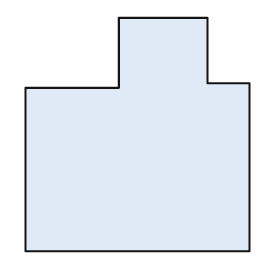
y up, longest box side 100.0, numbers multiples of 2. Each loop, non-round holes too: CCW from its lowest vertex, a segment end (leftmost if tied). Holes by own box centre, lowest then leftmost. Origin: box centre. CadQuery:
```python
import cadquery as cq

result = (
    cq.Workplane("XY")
    .moveTo(-48.0, -50.0)
    .lineTo(48.0, -50.0)
    .lineTo(48.0, 22.0)
    .lineTo(30.0, 22.0)
    .lineTo(30.0, 50.0)
    .lineTo(-8.0, 50.0)
    .lineTo(-8.0, 20.0)
    .lineTo(-48.0, 20.0)
    .close()
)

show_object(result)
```